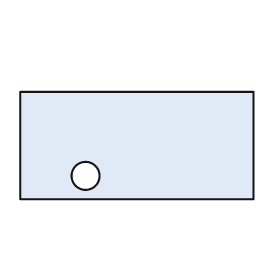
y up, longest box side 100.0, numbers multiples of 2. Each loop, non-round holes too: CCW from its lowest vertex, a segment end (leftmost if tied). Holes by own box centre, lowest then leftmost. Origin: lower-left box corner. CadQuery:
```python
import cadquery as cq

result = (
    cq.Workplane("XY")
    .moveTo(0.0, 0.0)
    .lineTo(100.0, 0.0)
    .lineTo(100.0, 46.0)
    .lineTo(0.0, 46.0)
    .close()
    .moveTo(28.0, 10.0)
    .circle(6.0)
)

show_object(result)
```